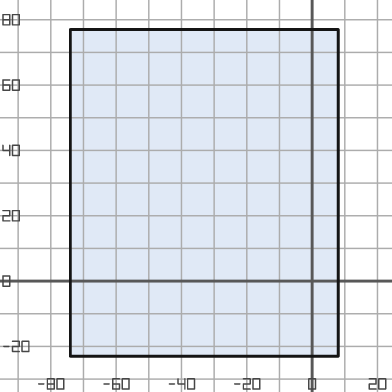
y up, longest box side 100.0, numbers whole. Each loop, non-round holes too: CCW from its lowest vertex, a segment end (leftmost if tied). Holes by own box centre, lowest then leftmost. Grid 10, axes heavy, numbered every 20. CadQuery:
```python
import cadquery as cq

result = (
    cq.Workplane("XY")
    .moveTo(-74.0, -23.0)
    .lineTo(8.0, -23.0)
    .lineTo(8.0, 77.0)
    .lineTo(-74.0, 77.0)
    .close()
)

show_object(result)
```